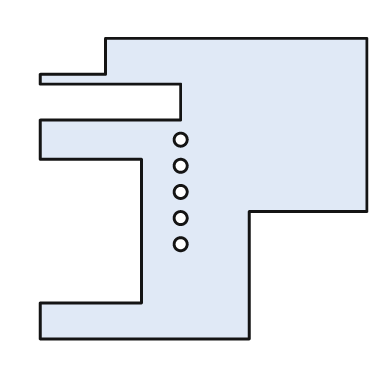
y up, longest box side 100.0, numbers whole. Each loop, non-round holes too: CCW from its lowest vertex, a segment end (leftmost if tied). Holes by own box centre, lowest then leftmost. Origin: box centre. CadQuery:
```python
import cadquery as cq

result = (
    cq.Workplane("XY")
    .moveTo(-50.0, -46.0)
    .lineTo(14.0, -46.0)
    .lineTo(14.0, -7.0)
    .lineTo(50.0, -7.0)
    .lineTo(50.0, 46.0)
    .lineTo(-30.0, 46.0)
    .lineTo(-30.0, 35.0)
    .lineTo(-50.0, 35.0)
    .lineTo(-50.0, 32.0)
    .lineTo(-7.0, 32.0)
    .lineTo(-7.0, 21.0)
    .lineTo(-50.0, 21.0)
    .lineTo(-50.0, 9.0)
    .lineTo(-19.0, 9.0)
    .lineTo(-19.0, -35.0)
    .lineTo(-50.0, -35.0)
    .close()
    .moveTo(-7.0, -17.0)
    .circle(2.0)
    .moveTo(-7.0, -9.0)
    .circle(2.0)
    .moveTo(-7.0, -1.0)
    .circle(2.0)
    .moveTo(-7.0, 7.0)
    .circle(2.0)
    .moveTo(-7.0, 15.0)
    .circle(2.0)
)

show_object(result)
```